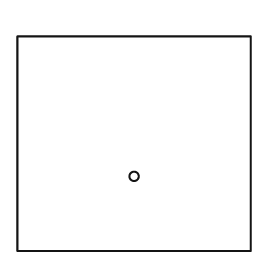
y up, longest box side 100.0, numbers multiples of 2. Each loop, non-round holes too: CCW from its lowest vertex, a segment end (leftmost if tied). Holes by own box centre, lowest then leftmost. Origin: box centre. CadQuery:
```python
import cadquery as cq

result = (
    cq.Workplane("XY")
    .moveTo(-50.0, -46.0)
    .lineTo(50.0, -46.0)
    .lineTo(50.0, 46.0)
    .lineTo(-50.0, 46.0)
    .close()
    .moveTo(0.0, -14.0)
    .circle(2.0)
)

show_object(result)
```